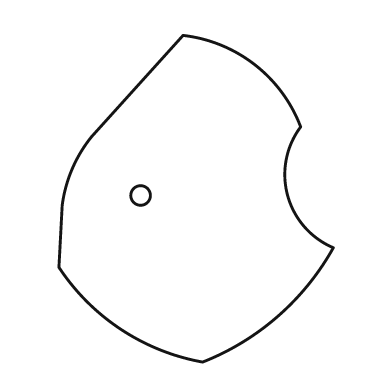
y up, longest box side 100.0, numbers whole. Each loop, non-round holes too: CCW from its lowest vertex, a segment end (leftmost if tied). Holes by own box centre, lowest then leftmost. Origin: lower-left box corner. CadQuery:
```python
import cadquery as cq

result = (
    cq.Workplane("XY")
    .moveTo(44.0, 0.0)
    .threePointArc((67.0, 14.0), (84.0, 35.0))
    .threePointArc((70.0, 51.0), (74.0, 72.0))
    .threePointArc((60.0, 91.0), (38.0, 100.0))
    .lineTo(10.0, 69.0)
    .threePointArc((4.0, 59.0), (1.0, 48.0))
    .lineTo(0.0, 29.0)
    .threePointArc((19.0, 10.0), (44.0, 0.0))
    .close()
    .moveTo(25.0, 51.0)
    .circle(3.0)
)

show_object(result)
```